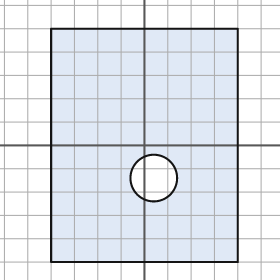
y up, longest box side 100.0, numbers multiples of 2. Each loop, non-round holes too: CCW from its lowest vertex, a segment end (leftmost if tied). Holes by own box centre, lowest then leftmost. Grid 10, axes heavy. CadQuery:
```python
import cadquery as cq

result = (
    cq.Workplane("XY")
    .moveTo(-40.0, -50.0)
    .lineTo(40.0, -50.0)
    .lineTo(40.0, 50.0)
    .lineTo(-40.0, 50.0)
    .close()
    .moveTo(4.0, -14.0)
    .circle(10.0)
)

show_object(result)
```